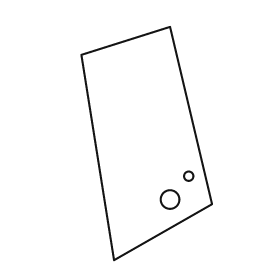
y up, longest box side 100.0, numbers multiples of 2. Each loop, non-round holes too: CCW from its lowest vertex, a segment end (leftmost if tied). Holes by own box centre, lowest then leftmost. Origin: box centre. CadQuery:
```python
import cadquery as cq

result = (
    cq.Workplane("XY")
    .moveTo(-14.0, -50.0)
    .lineTo(28.0, -26.0)
    .lineTo(10.0, 50.0)
    .lineTo(-28.0, 38.0)
    .close()
    .moveTo(10.0, -24.0)
    .circle(4.0)
    .moveTo(18.0, -14.0)
    .circle(2.0)
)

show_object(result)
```